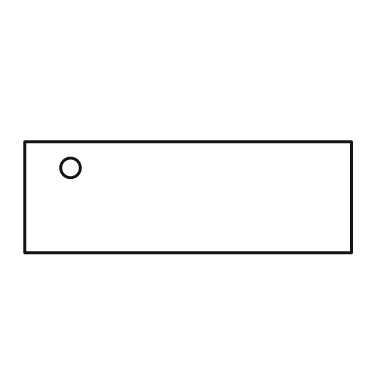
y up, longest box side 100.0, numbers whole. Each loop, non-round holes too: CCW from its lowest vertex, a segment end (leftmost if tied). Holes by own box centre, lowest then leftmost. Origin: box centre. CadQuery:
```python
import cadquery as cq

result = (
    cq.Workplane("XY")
    .moveTo(-50.0, -17.0)
    .lineTo(50.0, -17.0)
    .lineTo(50.0, 17.0)
    .lineTo(-50.0, 17.0)
    .close()
    .moveTo(-36.0, 9.0)
    .circle(3.0)
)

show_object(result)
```